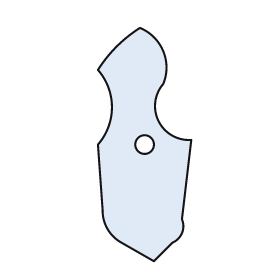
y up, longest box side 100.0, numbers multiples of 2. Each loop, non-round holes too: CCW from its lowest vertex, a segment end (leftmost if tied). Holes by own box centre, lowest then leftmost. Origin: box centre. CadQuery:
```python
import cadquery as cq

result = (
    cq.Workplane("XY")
    .moveTo(4.0, -50.0)
    .lineTo(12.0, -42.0)
    .threePointArc((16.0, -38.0), (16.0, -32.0))
    .lineTo(20.0, 2.0)
    .threePointArc((6.0, 10.0), (8.0, 26.0))
    .threePointArc((8.0, 40.0), (-2.0, 50.0))
    .threePointArc((-12.0, 42.0), (-20.0, 32.0))
    .threePointArc((-14.0, 16.0), (-20.0, 0.0))
    .lineTo(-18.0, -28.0)
    .threePointArc((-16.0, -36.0), (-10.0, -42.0))
    .close()
    .moveTo(0.0, 0.0)
    .circle(4.0)
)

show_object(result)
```